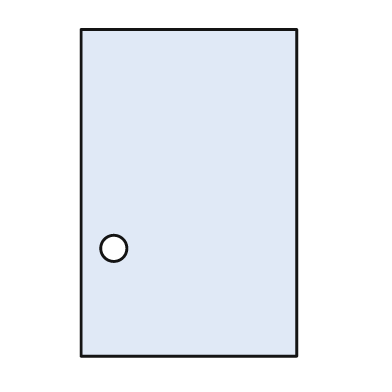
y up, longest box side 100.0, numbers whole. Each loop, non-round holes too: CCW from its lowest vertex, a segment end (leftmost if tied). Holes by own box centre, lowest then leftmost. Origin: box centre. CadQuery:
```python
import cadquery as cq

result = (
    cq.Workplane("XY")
    .moveTo(-33.0, -50.0)
    .lineTo(33.0, -50.0)
    .lineTo(33.0, 50.0)
    .lineTo(-33.0, 50.0)
    .close()
    .moveTo(-23.0, -17.0)
    .circle(4.0)
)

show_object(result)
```